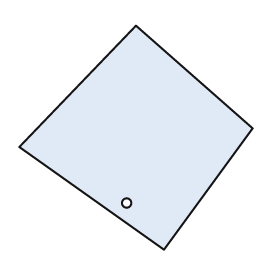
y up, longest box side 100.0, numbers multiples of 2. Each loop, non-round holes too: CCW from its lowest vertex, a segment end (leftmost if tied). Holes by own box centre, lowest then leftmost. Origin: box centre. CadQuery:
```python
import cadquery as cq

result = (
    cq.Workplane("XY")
    .moveTo(12.0, -48.0)
    .lineTo(50.0, 4.0)
    .lineTo(0.0, 48.0)
    .lineTo(-50.0, -4.0)
    .close()
    .moveTo(-4.0, -28.0)
    .circle(2.0)
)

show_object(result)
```